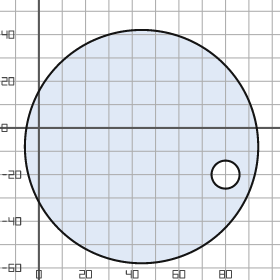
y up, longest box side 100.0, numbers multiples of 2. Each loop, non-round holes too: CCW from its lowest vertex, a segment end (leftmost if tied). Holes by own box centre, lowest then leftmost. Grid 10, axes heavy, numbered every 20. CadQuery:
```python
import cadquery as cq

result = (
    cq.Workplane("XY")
    .moveTo(44.0, -8.0)
    .circle(50.0)
    .moveTo(80.0, -20.0)
    .circle(6.0)
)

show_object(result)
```